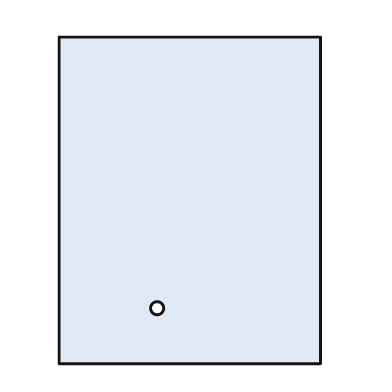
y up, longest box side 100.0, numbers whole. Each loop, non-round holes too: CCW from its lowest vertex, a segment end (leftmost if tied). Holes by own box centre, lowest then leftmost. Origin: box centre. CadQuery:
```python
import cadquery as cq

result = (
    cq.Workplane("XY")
    .moveTo(-40.0, -50.0)
    .lineTo(40.0, -50.0)
    .lineTo(40.0, 50.0)
    .lineTo(-40.0, 50.0)
    .close()
    .moveTo(-10.0, -33.0)
    .circle(2.0)
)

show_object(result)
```